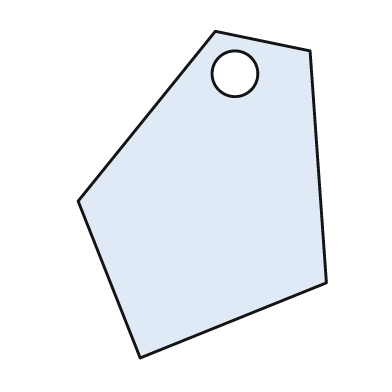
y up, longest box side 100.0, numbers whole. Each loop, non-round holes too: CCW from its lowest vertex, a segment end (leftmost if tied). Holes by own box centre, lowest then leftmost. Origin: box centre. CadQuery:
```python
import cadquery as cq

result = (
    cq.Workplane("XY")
    .moveTo(-19.0, -50.0)
    .lineTo(38.0, -27.0)
    .lineTo(33.0, 44.0)
    .lineTo(4.0, 50.0)
    .lineTo(-38.0, -2.0)
    .close()
    .moveTo(10.0, 37.0)
    .circle(7.0)
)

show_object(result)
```